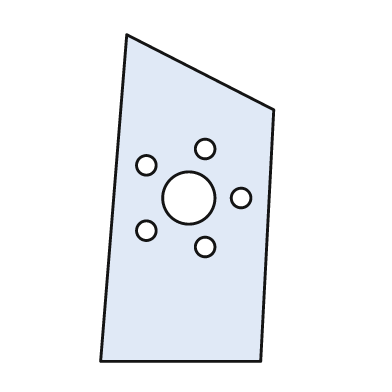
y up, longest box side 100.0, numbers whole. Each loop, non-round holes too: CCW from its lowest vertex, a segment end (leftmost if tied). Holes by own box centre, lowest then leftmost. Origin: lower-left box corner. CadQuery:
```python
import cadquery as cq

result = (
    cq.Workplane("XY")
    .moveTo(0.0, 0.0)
    .lineTo(49.0, 0.0)
    .lineTo(53.0, 77.0)
    .lineTo(8.0, 100.0)
    .close()
    .moveTo(32.0, 35.0)
    .circle(3.0)
    .moveTo(14.0, 40.0)
    .circle(3.0)
    .moveTo(27.0, 50.0)
    .circle(8.0)
    .moveTo(43.0, 50.0)
    .circle(3.0)
    .moveTo(14.0, 60.0)
    .circle(3.0)
    .moveTo(32.0, 65.0)
    .circle(3.0)
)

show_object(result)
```